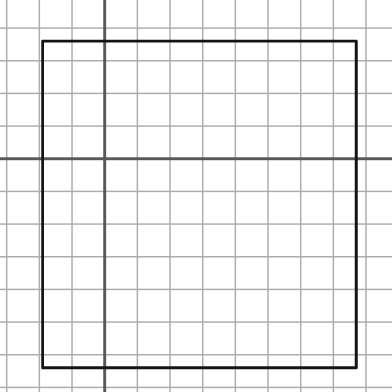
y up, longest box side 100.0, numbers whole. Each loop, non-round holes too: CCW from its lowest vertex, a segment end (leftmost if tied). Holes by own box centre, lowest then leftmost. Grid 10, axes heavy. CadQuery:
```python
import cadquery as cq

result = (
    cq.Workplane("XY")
    .moveTo(-19.0, -64.0)
    .lineTo(77.0, -64.0)
    .lineTo(77.0, 36.0)
    .lineTo(-19.0, 36.0)
    .close()
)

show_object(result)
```